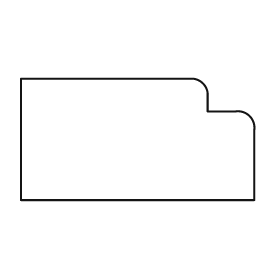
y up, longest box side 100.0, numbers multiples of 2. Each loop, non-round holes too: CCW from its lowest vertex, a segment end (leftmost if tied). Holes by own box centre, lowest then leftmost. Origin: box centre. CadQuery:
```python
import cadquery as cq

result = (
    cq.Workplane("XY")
    .moveTo(-50.0, -26.0)
    .lineTo(50.0, -26.0)
    .lineTo(50.0, 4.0)
    .threePointArc((48.0, 10.0), (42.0, 12.0))
    .lineTo(30.0, 12.0)
    .lineTo(30.0, 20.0)
    .threePointArc((28.0, 24.0), (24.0, 26.0))
    .lineTo(-50.0, 26.0)
    .close()
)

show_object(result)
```